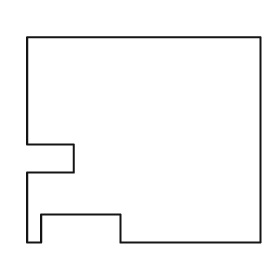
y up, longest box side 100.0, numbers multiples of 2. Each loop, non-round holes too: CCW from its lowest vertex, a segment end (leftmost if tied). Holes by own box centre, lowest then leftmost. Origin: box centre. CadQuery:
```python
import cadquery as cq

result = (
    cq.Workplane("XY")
    .moveTo(-50.0, -44.0)
    .lineTo(-44.0, -44.0)
    .lineTo(-44.0, -32.0)
    .lineTo(-10.0, -32.0)
    .lineTo(-10.0, -44.0)
    .lineTo(50.0, -44.0)
    .lineTo(50.0, 44.0)
    .lineTo(-50.0, 44.0)
    .lineTo(-50.0, -2.0)
    .lineTo(-30.0, -2.0)
    .lineTo(-30.0, -14.0)
    .lineTo(-50.0, -14.0)
    .close()
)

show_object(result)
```